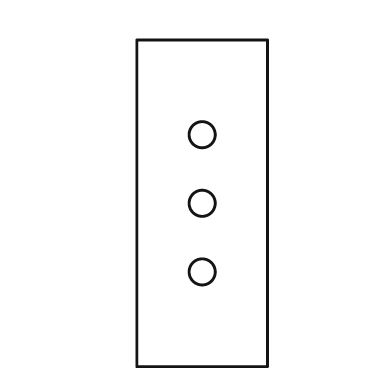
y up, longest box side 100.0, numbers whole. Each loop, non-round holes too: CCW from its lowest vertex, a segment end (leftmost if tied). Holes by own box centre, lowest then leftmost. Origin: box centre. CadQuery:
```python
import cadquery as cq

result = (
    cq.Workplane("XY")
    .moveTo(-20.0, -50.0)
    .lineTo(20.0, -50.0)
    .lineTo(20.0, 50.0)
    .lineTo(-20.0, 50.0)
    .close()
    .moveTo(0.0, -21.0)
    .circle(4.0)
    .moveTo(0.0, 0.0)
    .circle(4.0)
    .moveTo(0.0, 21.0)
    .circle(4.0)
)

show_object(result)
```